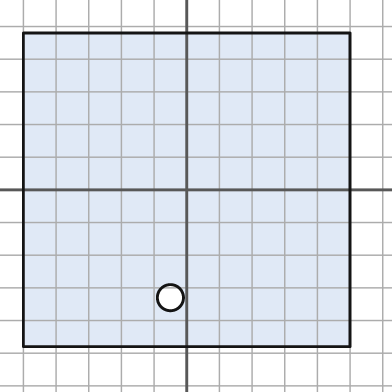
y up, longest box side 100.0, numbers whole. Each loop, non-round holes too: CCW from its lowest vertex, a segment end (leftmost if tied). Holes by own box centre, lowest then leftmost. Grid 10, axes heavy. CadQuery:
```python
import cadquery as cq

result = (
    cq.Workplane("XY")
    .moveTo(-50.0, -48.0)
    .lineTo(50.0, -48.0)
    .lineTo(50.0, 48.0)
    .lineTo(-50.0, 48.0)
    .close()
    .moveTo(-5.0, -33.0)
    .circle(4.0)
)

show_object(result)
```